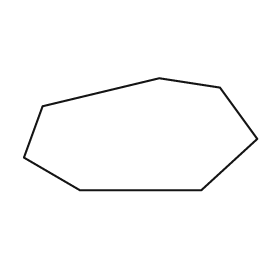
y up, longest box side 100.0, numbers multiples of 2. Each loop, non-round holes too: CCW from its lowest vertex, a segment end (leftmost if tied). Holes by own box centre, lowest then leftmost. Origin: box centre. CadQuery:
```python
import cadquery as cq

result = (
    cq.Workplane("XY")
    .moveTo(-26.0, -24.0)
    .lineTo(26.0, -24.0)
    .lineTo(50.0, -2.0)
    .lineTo(34.0, 20.0)
    .lineTo(8.0, 24.0)
    .lineTo(-42.0, 12.0)
    .lineTo(-50.0, -10.0)
    .close()
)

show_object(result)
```